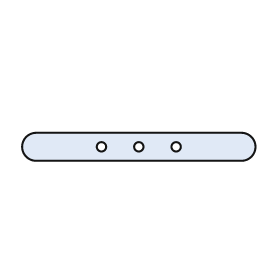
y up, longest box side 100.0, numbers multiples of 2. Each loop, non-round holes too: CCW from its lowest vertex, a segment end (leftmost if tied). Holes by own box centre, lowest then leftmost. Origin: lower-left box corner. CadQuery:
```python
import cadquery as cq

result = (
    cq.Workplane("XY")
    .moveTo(6.0, 0.0)
    .lineTo(94.0, 0.0)
    .threePointArc((100.0, 6.0), (94.0, 12.0))
    .lineTo(6.0, 12.0)
    .threePointArc((0.0, 6.0), (6.0, 0.0))
    .close()
    .moveTo(34.0, 6.0)
    .circle(2.0)
    .moveTo(50.0, 6.0)
    .circle(2.0)
    .moveTo(66.0, 6.0)
    .circle(2.0)
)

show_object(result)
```